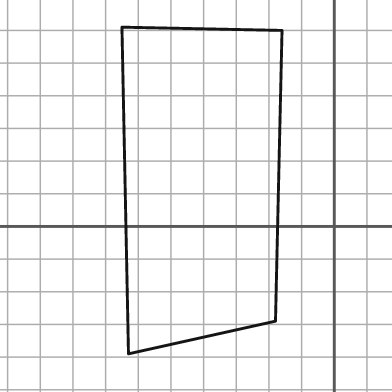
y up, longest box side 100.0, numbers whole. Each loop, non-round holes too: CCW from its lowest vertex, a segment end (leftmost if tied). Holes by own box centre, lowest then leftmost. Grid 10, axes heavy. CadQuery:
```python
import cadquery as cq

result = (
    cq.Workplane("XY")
    .moveTo(-63.0, -39.0)
    .lineTo(-18.0, -29.0)
    .lineTo(-16.0, 60.0)
    .lineTo(-65.0, 61.0)
    .close()
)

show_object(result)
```